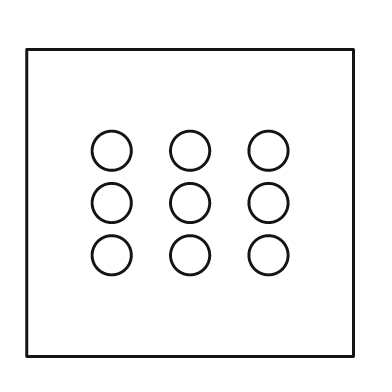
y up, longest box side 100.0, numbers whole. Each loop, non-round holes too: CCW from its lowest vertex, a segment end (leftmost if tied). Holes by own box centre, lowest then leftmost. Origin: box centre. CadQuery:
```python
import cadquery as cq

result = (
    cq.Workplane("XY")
    .moveTo(-50.0, -47.0)
    .lineTo(50.0, -47.0)
    .lineTo(50.0, 47.0)
    .lineTo(-50.0, 47.0)
    .close()
    .moveTo(-24.0, -16.0)
    .circle(6.0)
    .moveTo(0.0, -16.0)
    .circle(6.0)
    .moveTo(24.0, -16.0)
    .circle(6.0)
    .moveTo(-24.0, 0.0)
    .circle(6.0)
    .moveTo(0.0, 0.0)
    .circle(6.0)
    .moveTo(24.0, 0.0)
    .circle(6.0)
    .moveTo(-24.0, 16.0)
    .circle(6.0)
    .moveTo(0.0, 16.0)
    .circle(6.0)
    .moveTo(24.0, 16.0)
    .circle(6.0)
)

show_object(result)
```